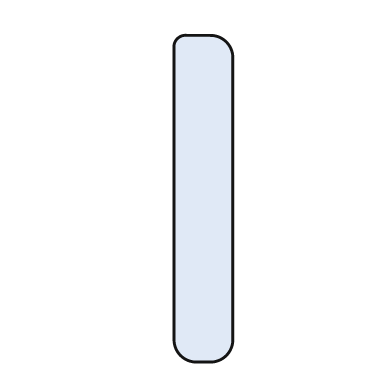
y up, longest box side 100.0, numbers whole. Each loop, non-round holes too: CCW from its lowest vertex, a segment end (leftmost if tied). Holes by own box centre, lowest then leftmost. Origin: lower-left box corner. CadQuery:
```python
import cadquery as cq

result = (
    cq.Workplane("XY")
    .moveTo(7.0, 0.0)
    .lineTo(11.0, 0.0)
    .threePointArc((16.0, 2.0), (18.0, 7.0))
    .lineTo(18.0, 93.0)
    .threePointArc((16.0, 98.0), (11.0, 100.0))
    .lineTo(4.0, 100.0)
    .threePointArc((1.0, 99.0), (0.0, 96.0))
    .lineTo(0.0, 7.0)
    .threePointArc((2.0, 2.0), (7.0, 0.0))
    .close()
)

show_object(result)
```